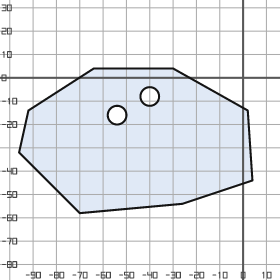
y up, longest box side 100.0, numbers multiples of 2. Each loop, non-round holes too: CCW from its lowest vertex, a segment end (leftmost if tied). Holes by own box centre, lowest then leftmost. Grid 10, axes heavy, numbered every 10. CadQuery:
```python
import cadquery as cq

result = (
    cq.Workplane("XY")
    .moveTo(-70.0, -58.0)
    .lineTo(-26.0, -54.0)
    .lineTo(4.0, -44.0)
    .lineTo(2.0, -14.0)
    .lineTo(-30.0, 4.0)
    .lineTo(-64.0, 4.0)
    .lineTo(-92.0, -14.0)
    .lineTo(-96.0, -32.0)
    .close()
    .moveTo(-54.0, -16.0)
    .circle(4.0)
    .moveTo(-40.0, -8.0)
    .circle(4.0)
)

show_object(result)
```